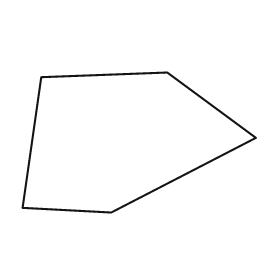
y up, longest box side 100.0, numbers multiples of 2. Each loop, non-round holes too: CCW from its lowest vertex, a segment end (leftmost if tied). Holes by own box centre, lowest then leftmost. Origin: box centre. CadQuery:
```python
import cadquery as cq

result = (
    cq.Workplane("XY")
    .moveTo(-12.0, -30.0)
    .lineTo(50.0, 2.0)
    .lineTo(12.0, 30.0)
    .lineTo(-42.0, 28.0)
    .lineTo(-50.0, -28.0)
    .close()
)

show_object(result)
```